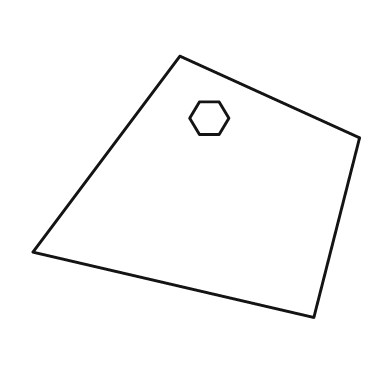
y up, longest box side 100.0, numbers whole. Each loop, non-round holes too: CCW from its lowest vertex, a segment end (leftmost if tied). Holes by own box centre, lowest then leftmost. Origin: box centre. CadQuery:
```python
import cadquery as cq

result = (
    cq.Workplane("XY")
    .moveTo(36.0, -40.0)
    .lineTo(50.0, 15.0)
    .lineTo(-5.0, 40.0)
    .lineTo(-50.0, -20.0)
    .close()
    .moveTo(1.0, 16.0)
    .lineTo(7.0, 16.0)
    .lineTo(10.0, 21.0)
    .lineTo(7.0, 26.0)
    .lineTo(1.0, 26.0)
    .lineTo(-2.0, 21.0)
    .close()
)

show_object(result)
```